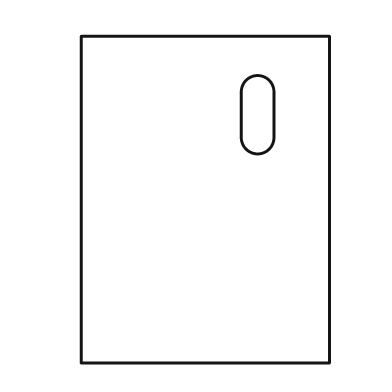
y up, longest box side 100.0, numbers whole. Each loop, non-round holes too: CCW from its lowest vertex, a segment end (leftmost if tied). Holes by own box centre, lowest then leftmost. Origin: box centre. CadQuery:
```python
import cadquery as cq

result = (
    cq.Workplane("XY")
    .moveTo(-38.0, -50.0)
    .lineTo(38.0, -50.0)
    .lineTo(38.0, 50.0)
    .lineTo(-38.0, 50.0)
    .close()
    .moveTo(11.0, 19.0)
    .threePointArc((16.0, 14.0), (21.0, 19.0))
    .lineTo(21.0, 33.0)
    .threePointArc((16.0, 38.0), (11.0, 33.0))
    .close()
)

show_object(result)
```